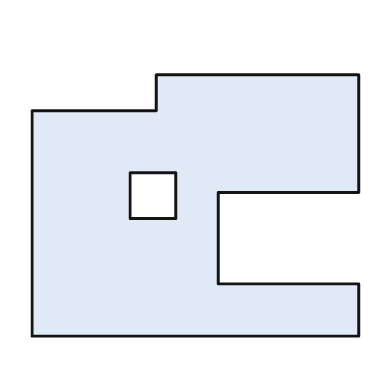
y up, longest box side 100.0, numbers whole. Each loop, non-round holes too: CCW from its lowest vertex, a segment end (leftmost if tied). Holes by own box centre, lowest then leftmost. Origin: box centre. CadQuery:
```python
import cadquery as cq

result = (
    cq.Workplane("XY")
    .moveTo(-50.0, -40.0)
    .lineTo(50.0, -40.0)
    .lineTo(50.0, -24.0)
    .lineTo(7.0, -24.0)
    .lineTo(7.0, 4.0)
    .lineTo(50.0, 4.0)
    .lineTo(50.0, 40.0)
    .lineTo(-12.0, 40.0)
    .lineTo(-12.0, 29.0)
    .lineTo(-50.0, 29.0)
    .close()
    .moveTo(-20.0, -4.0)
    .lineTo(-6.0, -4.0)
    .lineTo(-6.0, 10.0)
    .lineTo(-20.0, 10.0)
    .close()
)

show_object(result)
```